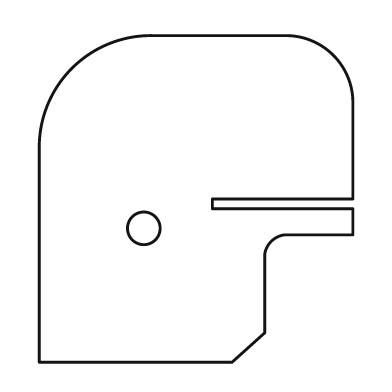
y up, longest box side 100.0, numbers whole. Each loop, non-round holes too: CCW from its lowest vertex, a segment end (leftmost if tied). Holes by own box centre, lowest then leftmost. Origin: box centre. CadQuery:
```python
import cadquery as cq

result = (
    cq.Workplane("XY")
    .moveTo(-48.0, -50.0)
    .lineTo(11.0, -50.0)
    .lineTo(21.0, -41.0)
    .lineTo(21.0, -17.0)
    .threePointArc((23.0, -13.0), (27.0, -11.0))
    .lineTo(48.0, -11.0)
    .lineTo(48.0, -3.0)
    .lineTo(5.0, -3.0)
    .lineTo(5.0, 0.0)
    .lineTo(48.0, 0.0)
    .lineTo(48.0, 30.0)
    .threePointArc((42.0, 44.0), (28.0, 50.0))
    .lineTo(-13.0, 50.0)
    .threePointArc((-38.0, 40.0), (-48.0, 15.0))
    .close()
    .moveTo(-16.0, -9.0)
    .circle(5.0)
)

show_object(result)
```